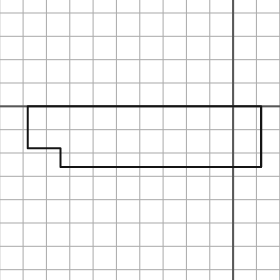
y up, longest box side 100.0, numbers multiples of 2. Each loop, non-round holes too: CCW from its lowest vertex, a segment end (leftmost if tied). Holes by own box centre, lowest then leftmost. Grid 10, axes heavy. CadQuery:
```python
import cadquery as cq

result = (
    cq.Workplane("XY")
    .moveTo(-74.0, -26.0)
    .lineTo(12.0, -26.0)
    .lineTo(12.0, 0.0)
    .lineTo(-88.0, 0.0)
    .lineTo(-88.0, -18.0)
    .lineTo(-74.0, -18.0)
    .close()
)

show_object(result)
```